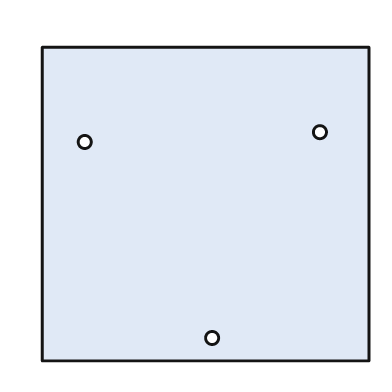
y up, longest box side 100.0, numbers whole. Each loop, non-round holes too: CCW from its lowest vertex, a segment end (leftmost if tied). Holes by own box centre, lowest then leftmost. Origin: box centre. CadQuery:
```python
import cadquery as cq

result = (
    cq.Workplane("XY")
    .moveTo(-50.0, -48.0)
    .lineTo(50.0, -48.0)
    .lineTo(50.0, 48.0)
    .lineTo(-50.0, 48.0)
    .close()
    .moveTo(2.0, -41.0)
    .circle(2.0)
    .moveTo(-37.0, 19.0)
    .circle(2.0)
    .moveTo(35.0, 22.0)
    .circle(2.0)
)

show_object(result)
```